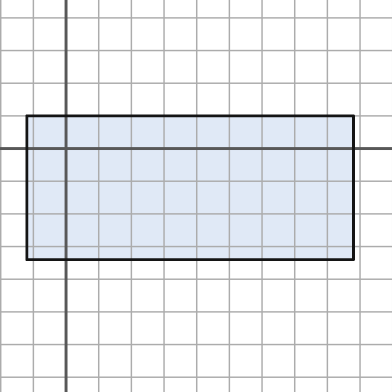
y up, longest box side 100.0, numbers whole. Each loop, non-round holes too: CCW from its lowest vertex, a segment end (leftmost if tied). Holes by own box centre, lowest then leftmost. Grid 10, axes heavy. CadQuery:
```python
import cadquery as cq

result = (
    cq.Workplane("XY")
    .moveTo(-12.0, -34.0)
    .lineTo(88.0, -34.0)
    .lineTo(88.0, 10.0)
    .lineTo(-12.0, 10.0)
    .close()
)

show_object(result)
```